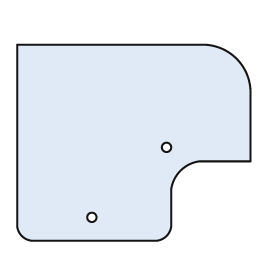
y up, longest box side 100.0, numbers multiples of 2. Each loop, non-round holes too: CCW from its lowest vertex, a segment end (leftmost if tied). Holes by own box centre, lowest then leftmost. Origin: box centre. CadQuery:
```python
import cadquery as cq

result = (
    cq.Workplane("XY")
    .moveTo(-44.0, -42.0)
    .lineTo(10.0, -42.0)
    .threePointArc((14.0, -40.0), (16.0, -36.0))
    .lineTo(16.0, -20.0)
    .threePointArc((20.0, -12.0), (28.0, -8.0))
    .lineTo(50.0, -8.0)
    .lineTo(50.0, 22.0)
    .threePointArc((44.0, 36.0), (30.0, 42.0))
    .lineTo(-50.0, 42.0)
    .lineTo(-50.0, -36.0)
    .threePointArc((-48.0, -40.0), (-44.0, -42.0))
    .close()
    .moveTo(-18.0, -32.0)
    .circle(2.0)
    .moveTo(14.0, -2.0)
    .circle(2.0)
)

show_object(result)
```